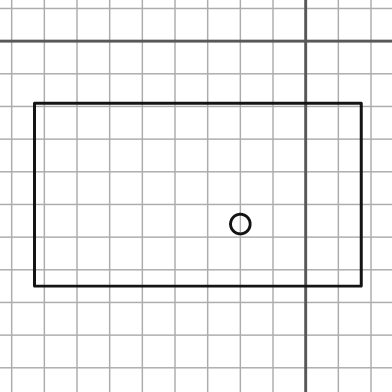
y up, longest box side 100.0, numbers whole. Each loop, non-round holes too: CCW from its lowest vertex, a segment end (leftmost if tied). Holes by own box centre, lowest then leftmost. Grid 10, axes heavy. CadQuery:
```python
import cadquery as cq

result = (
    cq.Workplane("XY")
    .moveTo(-83.0, -75.0)
    .lineTo(17.0, -75.0)
    .lineTo(17.0, -19.0)
    .lineTo(-83.0, -19.0)
    .close()
    .moveTo(-20.0, -56.0)
    .circle(3.0)
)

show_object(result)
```